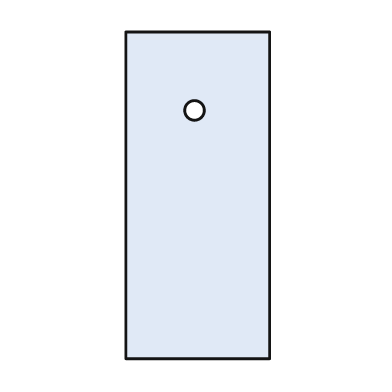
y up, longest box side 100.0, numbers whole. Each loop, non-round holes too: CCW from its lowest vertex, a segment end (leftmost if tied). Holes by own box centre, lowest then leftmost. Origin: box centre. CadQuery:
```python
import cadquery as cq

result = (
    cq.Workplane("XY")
    .moveTo(-22.0, -50.0)
    .lineTo(22.0, -50.0)
    .lineTo(22.0, 50.0)
    .lineTo(-22.0, 50.0)
    .close()
    .moveTo(-1.0, 26.0)
    .circle(3.0)
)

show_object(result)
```